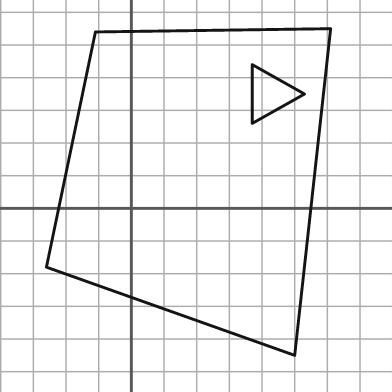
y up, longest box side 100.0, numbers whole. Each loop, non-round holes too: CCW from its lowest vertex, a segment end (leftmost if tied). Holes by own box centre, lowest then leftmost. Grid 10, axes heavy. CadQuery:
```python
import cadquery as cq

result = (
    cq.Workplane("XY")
    .moveTo(50.0, -45.0)
    .lineTo(61.0, 55.0)
    .lineTo(-11.0, 54.0)
    .lineTo(-26.0, -18.0)
    .close()
    .moveTo(37.0, 26.0)
    .lineTo(53.0, 35.0)
    .lineTo(37.0, 44.0)
    .close()
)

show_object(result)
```